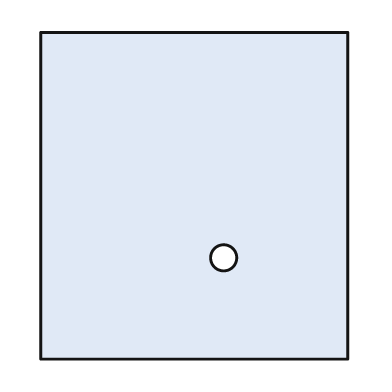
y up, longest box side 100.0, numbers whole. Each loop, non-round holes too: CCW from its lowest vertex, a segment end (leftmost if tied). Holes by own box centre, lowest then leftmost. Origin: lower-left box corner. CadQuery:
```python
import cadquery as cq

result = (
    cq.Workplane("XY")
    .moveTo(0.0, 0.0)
    .lineTo(94.0, 0.0)
    .lineTo(94.0, 100.0)
    .lineTo(0.0, 100.0)
    .close()
    .moveTo(56.0, 31.0)
    .circle(4.0)
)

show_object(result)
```